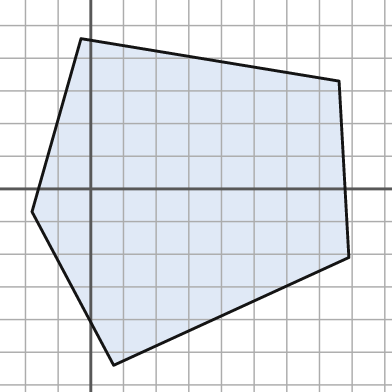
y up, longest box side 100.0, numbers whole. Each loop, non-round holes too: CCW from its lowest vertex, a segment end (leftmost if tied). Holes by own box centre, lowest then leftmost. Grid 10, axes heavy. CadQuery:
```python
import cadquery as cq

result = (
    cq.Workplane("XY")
    .moveTo(7.0, -54.0)
    .lineTo(79.0, -21.0)
    .lineTo(76.0, 33.0)
    .lineTo(-3.0, 46.0)
    .lineTo(-18.0, -7.0)
    .close()
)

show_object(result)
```